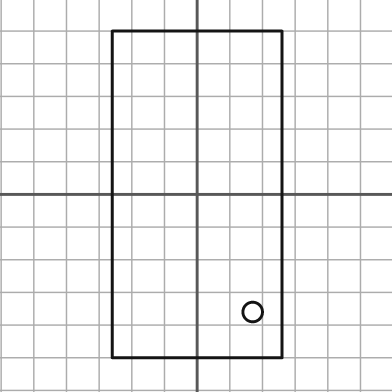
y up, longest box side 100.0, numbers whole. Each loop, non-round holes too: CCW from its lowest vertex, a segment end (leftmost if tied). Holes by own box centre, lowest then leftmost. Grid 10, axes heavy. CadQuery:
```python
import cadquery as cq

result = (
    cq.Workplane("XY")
    .moveTo(-26.0, -50.0)
    .lineTo(26.0, -50.0)
    .lineTo(26.0, 50.0)
    .lineTo(-26.0, 50.0)
    .close()
    .moveTo(17.0, -36.0)
    .circle(3.0)
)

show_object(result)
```